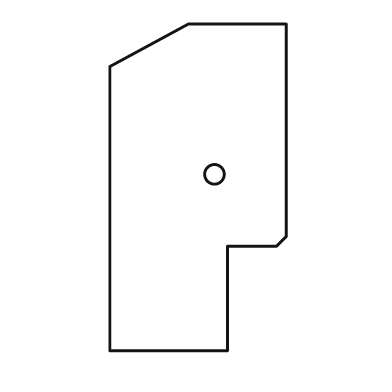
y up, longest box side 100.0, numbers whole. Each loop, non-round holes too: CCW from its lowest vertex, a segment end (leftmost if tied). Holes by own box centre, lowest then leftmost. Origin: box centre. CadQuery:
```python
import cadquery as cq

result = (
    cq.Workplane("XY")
    .moveTo(-27.0, -50.0)
    .lineTo(9.0, -50.0)
    .lineTo(9.0, -18.0)
    .lineTo(24.0, -18.0)
    .lineTo(27.0, -15.0)
    .lineTo(27.0, 50.0)
    .lineTo(-3.0, 50.0)
    .lineTo(-27.0, 37.0)
    .close()
    .moveTo(5.0, 4.0)
    .circle(3.0)
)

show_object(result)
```